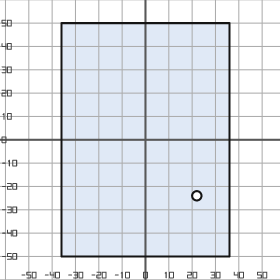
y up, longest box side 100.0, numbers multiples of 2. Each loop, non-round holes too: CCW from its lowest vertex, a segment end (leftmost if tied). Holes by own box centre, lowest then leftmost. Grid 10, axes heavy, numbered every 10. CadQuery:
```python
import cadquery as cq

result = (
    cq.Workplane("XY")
    .moveTo(-36.0, -50.0)
    .lineTo(36.0, -50.0)
    .lineTo(36.0, 50.0)
    .lineTo(-36.0, 50.0)
    .close()
    .moveTo(22.0, -24.0)
    .circle(2.0)
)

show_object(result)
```